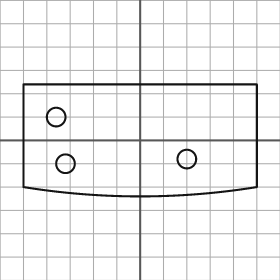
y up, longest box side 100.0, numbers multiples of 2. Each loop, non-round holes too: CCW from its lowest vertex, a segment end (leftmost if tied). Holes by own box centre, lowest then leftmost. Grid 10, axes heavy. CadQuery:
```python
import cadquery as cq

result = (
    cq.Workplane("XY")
    .moveTo(-50.0, -20.0)
    .threePointArc((0.0, -24.0), (50.0, -20.0))
    .lineTo(50.0, 24.0)
    .lineTo(-50.0, 24.0)
    .close()
    .moveTo(-32.0, -10.0)
    .circle(4.0)
    .moveTo(20.0, -8.0)
    .circle(4.0)
    .moveTo(-36.0, 10.0)
    .circle(4.0)
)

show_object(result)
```